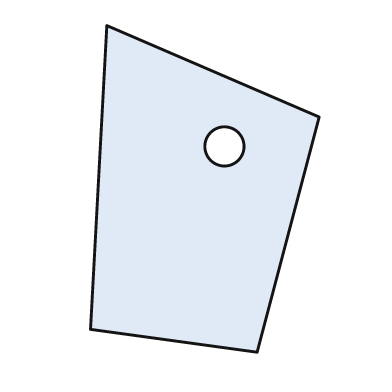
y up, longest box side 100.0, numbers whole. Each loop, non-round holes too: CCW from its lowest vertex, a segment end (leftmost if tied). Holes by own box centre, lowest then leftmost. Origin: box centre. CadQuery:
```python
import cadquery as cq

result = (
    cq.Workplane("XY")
    .moveTo(16.0, -50.0)
    .lineTo(35.0, 22.0)
    .lineTo(-30.0, 50.0)
    .lineTo(-35.0, -43.0)
    .close()
    .moveTo(6.0, 13.0)
    .circle(6.0)
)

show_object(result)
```